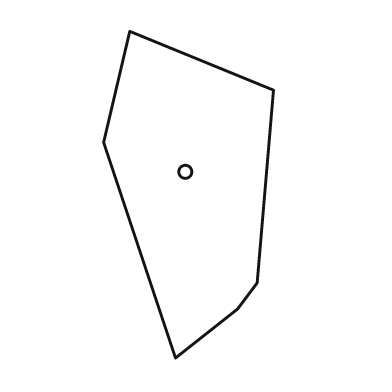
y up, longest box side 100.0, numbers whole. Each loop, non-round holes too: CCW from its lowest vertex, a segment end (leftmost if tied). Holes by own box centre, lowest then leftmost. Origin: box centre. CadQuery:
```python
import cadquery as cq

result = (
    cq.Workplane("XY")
    .moveTo(-4.0, -50.0)
    .lineTo(15.0, -35.0)
    .lineTo(21.0, -27.0)
    .lineTo(26.0, 32.0)
    .lineTo(-18.0, 50.0)
    .lineTo(-26.0, 16.0)
    .close()
    .moveTo(-1.0, 7.0)
    .circle(2.0)
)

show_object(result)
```